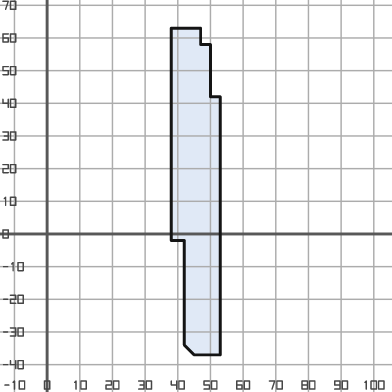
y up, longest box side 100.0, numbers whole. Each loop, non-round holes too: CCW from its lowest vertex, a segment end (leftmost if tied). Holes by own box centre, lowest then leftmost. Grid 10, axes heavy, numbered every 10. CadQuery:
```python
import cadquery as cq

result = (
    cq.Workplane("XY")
    .moveTo(45.0, -37.0)
    .lineTo(53.0, -37.0)
    .lineTo(53.0, 42.0)
    .lineTo(50.0, 42.0)
    .lineTo(50.0, 58.0)
    .lineTo(47.0, 58.0)
    .lineTo(47.0, 63.0)
    .lineTo(38.0, 63.0)
    .lineTo(38.0, -2.0)
    .lineTo(42.0, -2.0)
    .lineTo(42.0, -34.0)
    .close()
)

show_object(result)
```